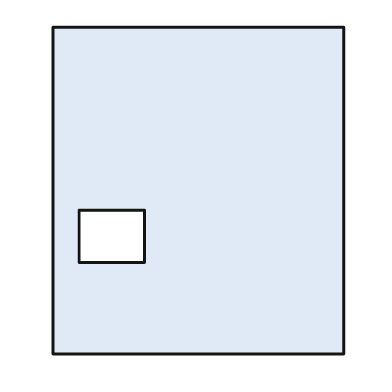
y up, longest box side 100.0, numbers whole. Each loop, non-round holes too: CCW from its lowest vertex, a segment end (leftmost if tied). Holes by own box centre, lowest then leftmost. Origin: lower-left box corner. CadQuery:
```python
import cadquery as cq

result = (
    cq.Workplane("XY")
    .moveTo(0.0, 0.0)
    .lineTo(89.0, 0.0)
    .lineTo(89.0, 100.0)
    .lineTo(0.0, 100.0)
    .close()
    .moveTo(8.0, 28.0)
    .lineTo(28.0, 28.0)
    .lineTo(28.0, 44.0)
    .lineTo(8.0, 44.0)
    .close()
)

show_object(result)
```